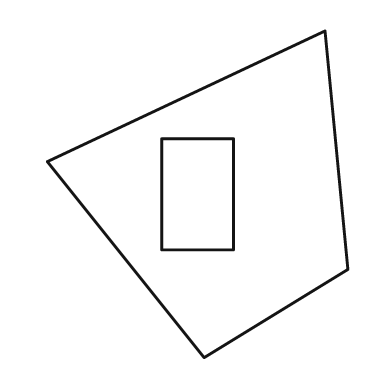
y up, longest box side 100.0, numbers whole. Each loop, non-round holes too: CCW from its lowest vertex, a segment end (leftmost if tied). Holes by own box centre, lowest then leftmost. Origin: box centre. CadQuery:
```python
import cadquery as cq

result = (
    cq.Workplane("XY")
    .moveTo(2.0, -50.0)
    .lineTo(46.0, -23.0)
    .lineTo(39.0, 50.0)
    .lineTo(-46.0, 10.0)
    .close()
    .moveTo(-11.0, -17.0)
    .lineTo(11.0, -17.0)
    .lineTo(11.0, 17.0)
    .lineTo(-11.0, 17.0)
    .close()
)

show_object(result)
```